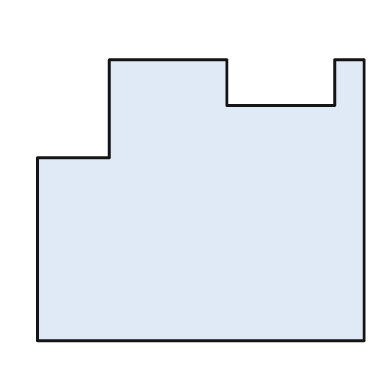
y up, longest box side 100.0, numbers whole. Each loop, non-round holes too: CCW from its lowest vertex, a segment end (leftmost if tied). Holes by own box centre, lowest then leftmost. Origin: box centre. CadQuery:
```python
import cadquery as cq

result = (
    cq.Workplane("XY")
    .moveTo(-50.0, -43.0)
    .lineTo(50.0, -43.0)
    .lineTo(50.0, 43.0)
    .lineTo(41.0, 43.0)
    .lineTo(41.0, 29.0)
    .lineTo(8.0, 29.0)
    .lineTo(8.0, 43.0)
    .lineTo(-28.0, 43.0)
    .lineTo(-28.0, 13.0)
    .lineTo(-50.0, 13.0)
    .close()
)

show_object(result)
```